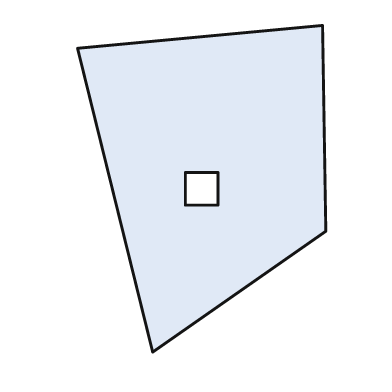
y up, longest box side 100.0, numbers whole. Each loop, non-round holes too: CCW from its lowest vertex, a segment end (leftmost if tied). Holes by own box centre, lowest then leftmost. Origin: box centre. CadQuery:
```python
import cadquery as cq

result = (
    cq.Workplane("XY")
    .moveTo(-15.0, -50.0)
    .lineTo(38.0, -13.0)
    .lineTo(37.0, 50.0)
    .lineTo(-38.0, 43.0)
    .close()
    .moveTo(-5.0, -5.0)
    .lineTo(5.0, -5.0)
    .lineTo(5.0, 5.0)
    .lineTo(-5.0, 5.0)
    .close()
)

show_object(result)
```